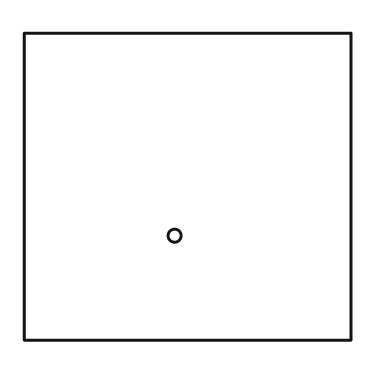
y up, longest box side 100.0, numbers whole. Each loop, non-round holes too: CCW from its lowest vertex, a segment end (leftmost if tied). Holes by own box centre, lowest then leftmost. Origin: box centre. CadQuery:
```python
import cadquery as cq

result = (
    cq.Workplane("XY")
    .moveTo(-50.0, -47.0)
    .lineTo(50.0, -47.0)
    .lineTo(50.0, 47.0)
    .lineTo(-50.0, 47.0)
    .close()
    .moveTo(-4.0, -15.0)
    .circle(2.0)
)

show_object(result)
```